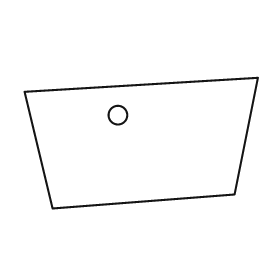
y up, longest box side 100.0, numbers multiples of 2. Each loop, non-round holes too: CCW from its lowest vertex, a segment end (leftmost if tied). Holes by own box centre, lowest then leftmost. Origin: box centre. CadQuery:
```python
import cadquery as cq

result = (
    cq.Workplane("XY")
    .moveTo(-38.0, -28.0)
    .lineTo(40.0, -22.0)
    .lineTo(50.0, 28.0)
    .lineTo(-50.0, 22.0)
    .close()
    .moveTo(-10.0, 12.0)
    .circle(4.0)
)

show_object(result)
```